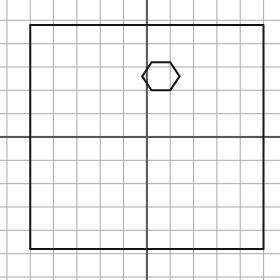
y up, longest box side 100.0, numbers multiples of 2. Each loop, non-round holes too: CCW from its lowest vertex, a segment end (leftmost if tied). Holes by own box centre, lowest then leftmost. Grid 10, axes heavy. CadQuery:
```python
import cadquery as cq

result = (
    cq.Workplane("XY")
    .moveTo(-50.0, -48.0)
    .lineTo(50.0, -48.0)
    .lineTo(50.0, 48.0)
    .lineTo(-50.0, 48.0)
    .close()
    .moveTo(2.0, 20.0)
    .lineTo(10.0, 20.0)
    .lineTo(14.0, 26.0)
    .lineTo(10.0, 32.0)
    .lineTo(2.0, 32.0)
    .lineTo(-2.0, 26.0)
    .close()
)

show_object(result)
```